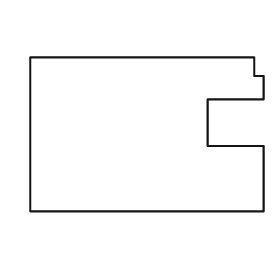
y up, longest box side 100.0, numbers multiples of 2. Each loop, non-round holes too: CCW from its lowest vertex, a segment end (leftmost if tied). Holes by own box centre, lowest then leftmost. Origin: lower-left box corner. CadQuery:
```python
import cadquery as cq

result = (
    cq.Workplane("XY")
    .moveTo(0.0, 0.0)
    .lineTo(100.0, 0.0)
    .lineTo(100.0, 28.0)
    .lineTo(76.0, 28.0)
    .lineTo(76.0, 48.0)
    .lineTo(100.0, 48.0)
    .lineTo(100.0, 58.0)
    .lineTo(96.0, 58.0)
    .lineTo(96.0, 66.0)
    .lineTo(0.0, 66.0)
    .close()
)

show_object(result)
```